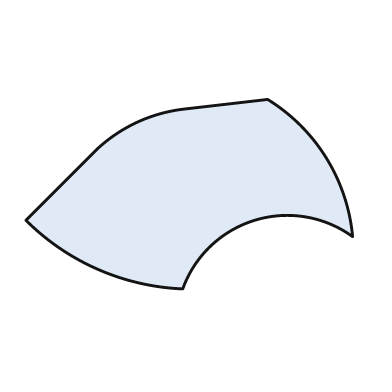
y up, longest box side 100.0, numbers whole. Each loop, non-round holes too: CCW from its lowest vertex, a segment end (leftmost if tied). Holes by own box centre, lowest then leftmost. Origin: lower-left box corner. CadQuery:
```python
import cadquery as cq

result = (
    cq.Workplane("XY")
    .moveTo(48.0, 0.0)
    .threePointArc((70.0, 21.0), (100.0, 16.0))
    .threePointArc((92.0, 40.0), (74.0, 58.0))
    .lineTo(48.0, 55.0)
    .threePointArc((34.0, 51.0), (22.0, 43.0))
    .lineTo(0.0, 21.0)
    .threePointArc((22.0, 6.0), (48.0, 0.0))
    .close()
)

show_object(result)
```